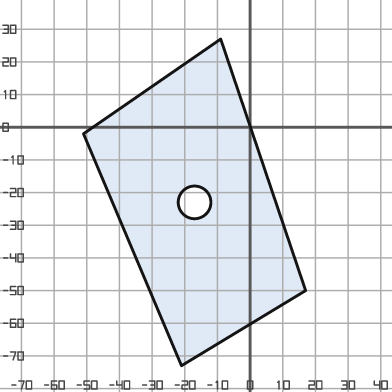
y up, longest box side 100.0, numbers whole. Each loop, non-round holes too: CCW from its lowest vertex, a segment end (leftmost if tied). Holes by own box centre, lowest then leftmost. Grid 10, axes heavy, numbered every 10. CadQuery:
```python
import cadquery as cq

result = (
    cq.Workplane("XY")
    .moveTo(-21.0, -73.0)
    .lineTo(17.0, -50.0)
    .lineTo(-9.0, 27.0)
    .lineTo(-51.0, -2.0)
    .close()
    .moveTo(-17.0, -23.0)
    .circle(5.0)
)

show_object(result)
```